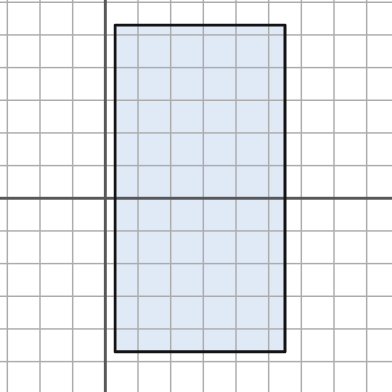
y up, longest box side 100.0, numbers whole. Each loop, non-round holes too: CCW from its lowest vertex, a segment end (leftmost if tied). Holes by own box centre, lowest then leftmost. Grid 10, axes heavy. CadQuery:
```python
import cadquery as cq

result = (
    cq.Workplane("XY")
    .moveTo(3.0, -47.0)
    .lineTo(55.0, -47.0)
    .lineTo(55.0, 53.0)
    .lineTo(3.0, 53.0)
    .close()
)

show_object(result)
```